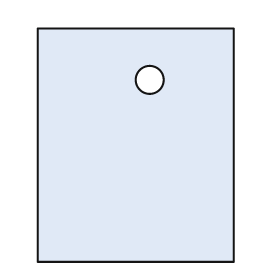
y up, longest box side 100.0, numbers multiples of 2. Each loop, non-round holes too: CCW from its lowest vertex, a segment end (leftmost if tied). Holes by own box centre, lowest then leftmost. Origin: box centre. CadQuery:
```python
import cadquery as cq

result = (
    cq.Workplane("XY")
    .moveTo(-42.0, -50.0)
    .lineTo(42.0, -50.0)
    .lineTo(42.0, 50.0)
    .lineTo(-42.0, 50.0)
    .close()
    .moveTo(6.0, 28.0)
    .circle(6.0)
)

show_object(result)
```